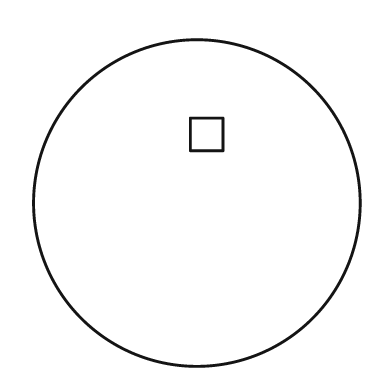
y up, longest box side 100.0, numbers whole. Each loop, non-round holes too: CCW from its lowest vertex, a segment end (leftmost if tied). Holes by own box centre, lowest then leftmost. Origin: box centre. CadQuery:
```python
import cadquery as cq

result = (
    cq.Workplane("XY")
    .moveTo(0.0, 0.0)
    .circle(50.0)
    .moveTo(-2.0, 16.0)
    .lineTo(8.0, 16.0)
    .lineTo(8.0, 26.0)
    .lineTo(-2.0, 26.0)
    .close()
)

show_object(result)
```